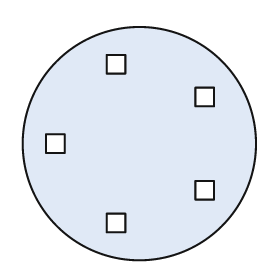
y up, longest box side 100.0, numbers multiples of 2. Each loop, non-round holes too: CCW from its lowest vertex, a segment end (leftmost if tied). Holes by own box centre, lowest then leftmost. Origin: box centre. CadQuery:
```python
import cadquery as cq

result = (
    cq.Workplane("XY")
    .moveTo(0.0, 0.0)
    .circle(50.0)
    .moveTo(-14.0, -38.0)
    .lineTo(-6.0, -38.0)
    .lineTo(-6.0, -30.0)
    .lineTo(-14.0, -30.0)
    .close()
    .moveTo(24.0, -24.0)
    .lineTo(32.0, -24.0)
    .lineTo(32.0, -16.0)
    .lineTo(24.0, -16.0)
    .close()
    .moveTo(-40.0, -4.0)
    .lineTo(-32.0, -4.0)
    .lineTo(-32.0, 4.0)
    .lineTo(-40.0, 4.0)
    .close()
    .moveTo(24.0, 16.0)
    .lineTo(32.0, 16.0)
    .lineTo(32.0, 24.0)
    .lineTo(24.0, 24.0)
    .close()
    .moveTo(-14.0, 30.0)
    .lineTo(-6.0, 30.0)
    .lineTo(-6.0, 38.0)
    .lineTo(-14.0, 38.0)
    .close()
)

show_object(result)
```